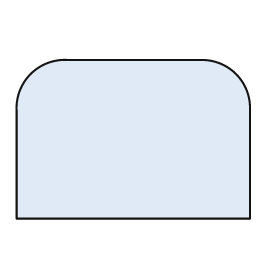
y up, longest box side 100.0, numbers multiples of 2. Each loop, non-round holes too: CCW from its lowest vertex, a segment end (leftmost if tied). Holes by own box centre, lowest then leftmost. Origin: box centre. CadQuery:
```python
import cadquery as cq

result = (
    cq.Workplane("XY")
    .moveTo(-50.0, -34.0)
    .lineTo(50.0, -34.0)
    .lineTo(50.0, 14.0)
    .threePointArc((44.0, 28.0), (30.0, 34.0))
    .lineTo(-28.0, 34.0)
    .threePointArc((-44.0, 28.0), (-50.0, 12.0))
    .close()
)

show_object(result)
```